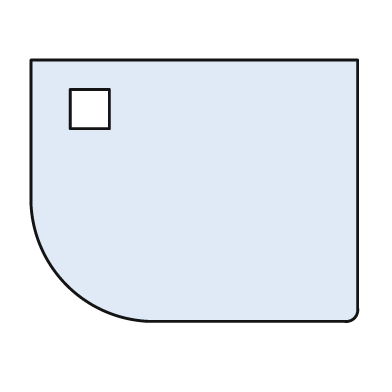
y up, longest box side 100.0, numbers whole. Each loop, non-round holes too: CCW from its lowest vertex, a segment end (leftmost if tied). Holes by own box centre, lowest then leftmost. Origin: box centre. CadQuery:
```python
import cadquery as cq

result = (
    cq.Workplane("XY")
    .moveTo(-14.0, -40.0)
    .lineTo(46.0, -40.0)
    .threePointArc((49.0, -39.0), (50.0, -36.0))
    .lineTo(50.0, 40.0)
    .lineTo(-50.0, 40.0)
    .lineTo(-50.0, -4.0)
    .threePointArc((-39.0, -29.0), (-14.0, -40.0))
    .close()
    .moveTo(-38.0, 19.0)
    .lineTo(-26.0, 19.0)
    .lineTo(-26.0, 31.0)
    .lineTo(-38.0, 31.0)
    .close()
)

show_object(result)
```